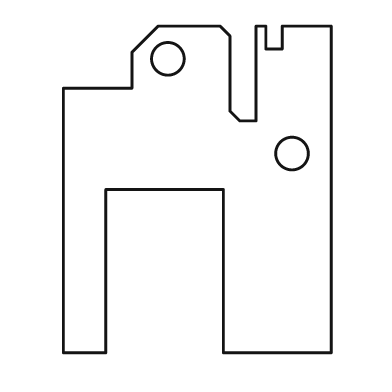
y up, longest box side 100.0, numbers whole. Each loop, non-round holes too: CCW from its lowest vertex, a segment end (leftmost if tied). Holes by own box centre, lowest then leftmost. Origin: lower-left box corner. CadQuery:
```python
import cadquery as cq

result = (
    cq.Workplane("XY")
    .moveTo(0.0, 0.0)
    .lineTo(13.0, 0.0)
    .lineTo(13.0, 50.0)
    .lineTo(49.0, 50.0)
    .lineTo(49.0, 0.0)
    .lineTo(82.0, 0.0)
    .lineTo(82.0, 100.0)
    .lineTo(67.0, 100.0)
    .lineTo(67.0, 93.0)
    .lineTo(62.0, 93.0)
    .lineTo(62.0, 100.0)
    .lineTo(59.0, 100.0)
    .lineTo(59.0, 71.0)
    .lineTo(54.0, 71.0)
    .lineTo(51.0, 74.0)
    .lineTo(51.0, 97.0)
    .lineTo(48.0, 100.0)
    .lineTo(29.0, 100.0)
    .lineTo(21.0, 92.0)
    .lineTo(21.0, 81.0)
    .lineTo(0.0, 81.0)
    .close()
    .moveTo(70.0, 61.0)
    .circle(5.0)
    .moveTo(32.0, 90.0)
    .circle(5.0)
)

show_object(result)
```